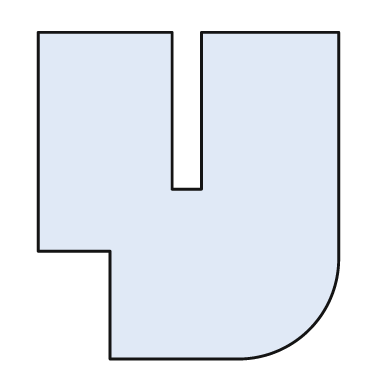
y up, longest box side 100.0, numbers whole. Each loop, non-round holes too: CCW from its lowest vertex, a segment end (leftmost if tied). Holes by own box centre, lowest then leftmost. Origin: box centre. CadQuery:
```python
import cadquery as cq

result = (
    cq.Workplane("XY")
    .moveTo(-24.0, -50.0)
    .lineTo(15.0, -50.0)
    .threePointArc((37.0, -41.0), (46.0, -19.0))
    .lineTo(46.0, 50.0)
    .lineTo(4.0, 50.0)
    .lineTo(4.0, 2.0)
    .lineTo(-5.0, 2.0)
    .lineTo(-5.0, 50.0)
    .lineTo(-46.0, 50.0)
    .lineTo(-46.0, -17.0)
    .lineTo(-24.0, -17.0)
    .close()
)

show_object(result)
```